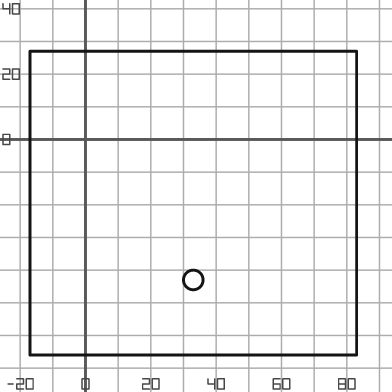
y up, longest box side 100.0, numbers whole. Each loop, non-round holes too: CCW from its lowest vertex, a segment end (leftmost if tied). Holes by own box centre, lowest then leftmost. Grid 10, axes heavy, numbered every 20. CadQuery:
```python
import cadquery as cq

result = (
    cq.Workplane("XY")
    .moveTo(-17.0, -66.0)
    .lineTo(83.0, -66.0)
    .lineTo(83.0, 27.0)
    .lineTo(-17.0, 27.0)
    .close()
    .moveTo(33.0, -43.0)
    .circle(3.0)
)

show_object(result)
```